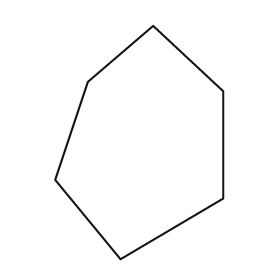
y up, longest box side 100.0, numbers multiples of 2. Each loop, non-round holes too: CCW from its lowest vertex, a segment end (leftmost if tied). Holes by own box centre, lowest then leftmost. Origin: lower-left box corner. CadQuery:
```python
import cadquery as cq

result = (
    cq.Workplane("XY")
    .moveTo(28.0, 0.0)
    .lineTo(72.0, 26.0)
    .lineTo(72.0, 72.0)
    .lineTo(42.0, 100.0)
    .lineTo(14.0, 76.0)
    .lineTo(0.0, 34.0)
    .close()
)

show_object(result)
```